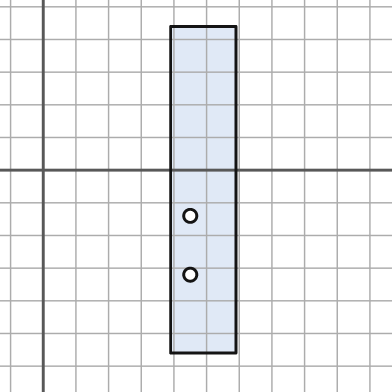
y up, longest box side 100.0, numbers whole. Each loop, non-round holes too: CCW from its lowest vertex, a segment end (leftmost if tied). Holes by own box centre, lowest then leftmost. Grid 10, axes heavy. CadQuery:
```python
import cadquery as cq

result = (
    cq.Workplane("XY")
    .moveTo(39.0, -56.0)
    .lineTo(59.0, -56.0)
    .lineTo(59.0, 44.0)
    .lineTo(39.0, 44.0)
    .close()
    .moveTo(45.0, -32.0)
    .circle(2.0)
    .moveTo(45.0, -14.0)
    .circle(2.0)
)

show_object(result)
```